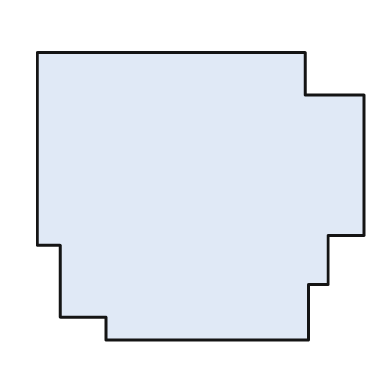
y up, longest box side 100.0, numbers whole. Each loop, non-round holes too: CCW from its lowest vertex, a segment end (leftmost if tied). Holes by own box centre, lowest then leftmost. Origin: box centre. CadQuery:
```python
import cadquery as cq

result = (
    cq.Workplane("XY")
    .moveTo(-29.0, -44.0)
    .lineTo(33.0, -44.0)
    .lineTo(33.0, -27.0)
    .lineTo(39.0, -27.0)
    .lineTo(39.0, -12.0)
    .lineTo(50.0, -12.0)
    .lineTo(50.0, 31.0)
    .lineTo(32.0, 31.0)
    .lineTo(32.0, 44.0)
    .lineTo(-50.0, 44.0)
    .lineTo(-50.0, -15.0)
    .lineTo(-43.0, -15.0)
    .lineTo(-43.0, -37.0)
    .lineTo(-29.0, -37.0)
    .close()
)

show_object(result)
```